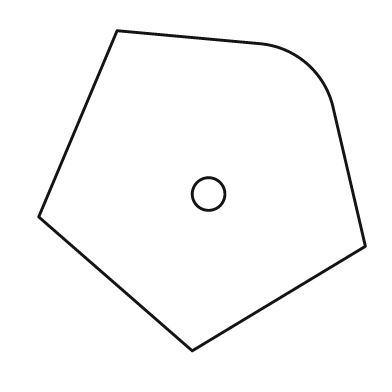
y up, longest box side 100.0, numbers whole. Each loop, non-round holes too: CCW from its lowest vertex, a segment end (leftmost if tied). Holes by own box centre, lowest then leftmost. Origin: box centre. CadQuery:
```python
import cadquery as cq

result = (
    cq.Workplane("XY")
    .moveTo(-3.0, -49.0)
    .lineTo(50.0, -17.0)
    .lineTo(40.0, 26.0)
    .threePointArc((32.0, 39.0), (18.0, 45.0))
    .lineTo(-26.0, 49.0)
    .lineTo(-50.0, -8.0)
    .close()
    .moveTo(2.0, -1.0)
    .circle(5.0)
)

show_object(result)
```